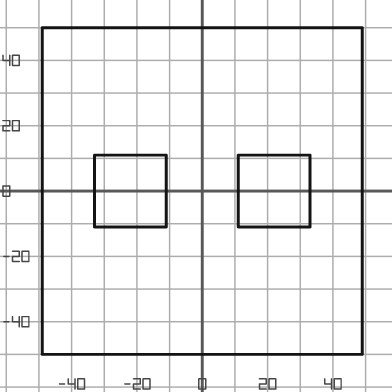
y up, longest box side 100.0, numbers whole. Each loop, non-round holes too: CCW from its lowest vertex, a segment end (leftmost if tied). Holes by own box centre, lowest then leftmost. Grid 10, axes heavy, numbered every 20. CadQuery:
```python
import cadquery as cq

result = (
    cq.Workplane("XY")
    .moveTo(-49.0, -50.0)
    .lineTo(49.0, -50.0)
    .lineTo(49.0, 50.0)
    .lineTo(-49.0, 50.0)
    .close()
    .moveTo(-33.0, -11.0)
    .lineTo(-11.0, -11.0)
    .lineTo(-11.0, 11.0)
    .lineTo(-33.0, 11.0)
    .close()
    .moveTo(11.0, -11.0)
    .lineTo(33.0, -11.0)
    .lineTo(33.0, 11.0)
    .lineTo(11.0, 11.0)
    .close()
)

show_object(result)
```